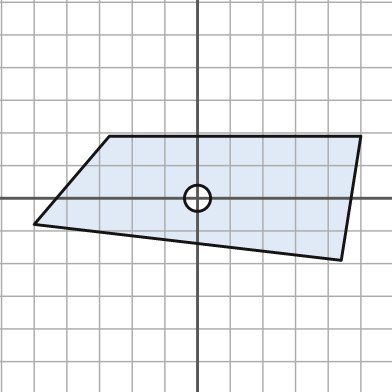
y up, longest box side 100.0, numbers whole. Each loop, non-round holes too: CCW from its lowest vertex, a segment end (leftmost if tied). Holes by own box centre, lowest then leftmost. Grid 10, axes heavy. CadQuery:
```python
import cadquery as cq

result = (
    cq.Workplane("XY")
    .moveTo(44.0, -19.0)
    .lineTo(50.0, 19.0)
    .lineTo(-27.0, 19.0)
    .lineTo(-50.0, -8.0)
    .close()
    .moveTo(0.0, 0.0)
    .circle(4.0)
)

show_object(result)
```